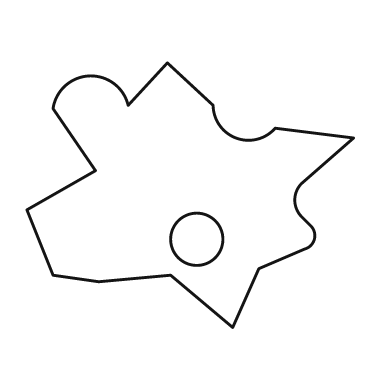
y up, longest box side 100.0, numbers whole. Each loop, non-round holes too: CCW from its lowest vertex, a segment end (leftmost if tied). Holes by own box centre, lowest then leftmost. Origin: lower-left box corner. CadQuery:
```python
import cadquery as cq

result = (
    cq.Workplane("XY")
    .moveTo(63.0, 0.0)
    .lineTo(71.0, 18.0)
    .lineTo(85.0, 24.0)
    .threePointArc((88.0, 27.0), (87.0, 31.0))
    .lineTo(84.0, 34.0)
    .threePointArc((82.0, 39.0), (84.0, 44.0))
    .lineTo(100.0, 58.0)
    .lineTo(76.0, 61.0)
    .threePointArc((64.0, 58.0), (57.0, 68.0))
    .lineTo(43.0, 81.0)
    .lineTo(31.0, 68.0)
    .threePointArc((19.0, 77.0), (8.0, 67.0))
    .lineTo(21.0, 48.0)
    .lineTo(0.0, 36.0)
    .lineTo(8.0, 16.0)
    .lineTo(22.0, 14.0)
    .lineTo(44.0, 16.0)
    .close()
    .moveTo(52.0, 27.0)
    .circle(8.0)
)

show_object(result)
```